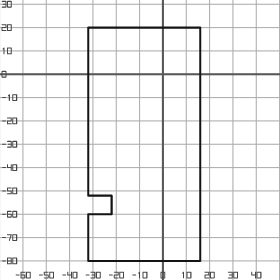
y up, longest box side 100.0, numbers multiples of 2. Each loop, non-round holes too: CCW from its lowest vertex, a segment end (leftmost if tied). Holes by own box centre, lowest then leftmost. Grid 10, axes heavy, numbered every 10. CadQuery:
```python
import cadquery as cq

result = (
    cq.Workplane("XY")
    .moveTo(-32.0, -80.0)
    .lineTo(16.0, -80.0)
    .lineTo(16.0, 20.0)
    .lineTo(-32.0, 20.0)
    .lineTo(-32.0, -52.0)
    .lineTo(-22.0, -52.0)
    .lineTo(-22.0, -60.0)
    .lineTo(-32.0, -60.0)
    .close()
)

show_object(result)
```